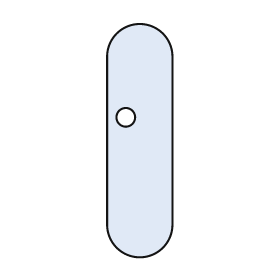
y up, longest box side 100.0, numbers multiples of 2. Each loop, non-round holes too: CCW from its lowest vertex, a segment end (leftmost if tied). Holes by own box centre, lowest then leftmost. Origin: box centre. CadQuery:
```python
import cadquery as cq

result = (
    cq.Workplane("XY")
    .moveTo(-14.0, -36.0)
    .threePointArc((0.0, -50.0), (14.0, -36.0))
    .lineTo(14.0, 36.0)
    .threePointArc((0.0, 50.0), (-14.0, 36.0))
    .close()
    .moveTo(-6.0, 10.0)
    .circle(4.0)
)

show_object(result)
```